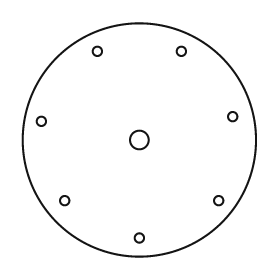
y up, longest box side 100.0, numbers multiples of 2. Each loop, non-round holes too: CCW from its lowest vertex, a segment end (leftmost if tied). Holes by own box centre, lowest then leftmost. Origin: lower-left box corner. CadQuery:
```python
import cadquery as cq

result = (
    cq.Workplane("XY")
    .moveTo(50.0, 50.0)
    .circle(50.0)
    .moveTo(50.0, 8.0)
    .circle(2.0)
    .moveTo(18.0, 24.0)
    .circle(2.0)
    .moveTo(84.0, 24.0)
    .circle(2.0)
    .moveTo(50.0, 50.0)
    .circle(4.0)
    .moveTo(8.0, 58.0)
    .circle(2.0)
    .moveTo(90.0, 60.0)
    .circle(2.0)
    .moveTo(32.0, 88.0)
    .circle(2.0)
    .moveTo(68.0, 88.0)
    .circle(2.0)
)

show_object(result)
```